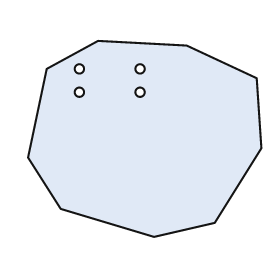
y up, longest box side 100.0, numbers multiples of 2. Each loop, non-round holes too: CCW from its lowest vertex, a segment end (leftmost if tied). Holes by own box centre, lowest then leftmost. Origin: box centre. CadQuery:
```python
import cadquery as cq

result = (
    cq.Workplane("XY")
    .moveTo(4.0, -42.0)
    .lineTo(30.0, -36.0)
    .lineTo(50.0, -4.0)
    .lineTo(48.0, 26.0)
    .lineTo(18.0, 40.0)
    .lineTo(-20.0, 42.0)
    .lineTo(-42.0, 30.0)
    .lineTo(-50.0, -8.0)
    .lineTo(-36.0, -30.0)
    .close()
    .moveTo(-28.0, 20.0)
    .circle(2.0)
    .moveTo(-2.0, 20.0)
    .circle(2.0)
    .moveTo(-28.0, 30.0)
    .circle(2.0)
    .moveTo(-2.0, 30.0)
    .circle(2.0)
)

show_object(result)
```